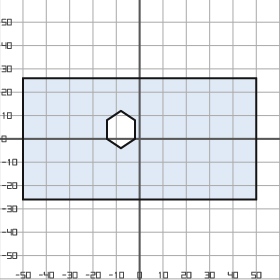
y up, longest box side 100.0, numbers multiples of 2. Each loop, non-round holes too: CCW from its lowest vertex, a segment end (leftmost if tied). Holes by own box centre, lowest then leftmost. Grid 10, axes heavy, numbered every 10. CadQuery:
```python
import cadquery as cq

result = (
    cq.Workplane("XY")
    .moveTo(-50.0, -26.0)
    .lineTo(50.0, -26.0)
    .lineTo(50.0, 26.0)
    .lineTo(-50.0, 26.0)
    .close()
    .moveTo(-8.0, -4.0)
    .lineTo(-2.0, 0.0)
    .lineTo(-2.0, 8.0)
    .lineTo(-8.0, 12.0)
    .lineTo(-14.0, 8.0)
    .lineTo(-14.0, 0.0)
    .close()
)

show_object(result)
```